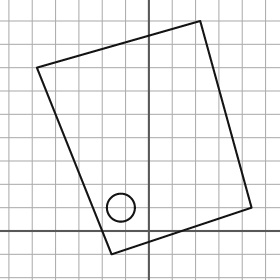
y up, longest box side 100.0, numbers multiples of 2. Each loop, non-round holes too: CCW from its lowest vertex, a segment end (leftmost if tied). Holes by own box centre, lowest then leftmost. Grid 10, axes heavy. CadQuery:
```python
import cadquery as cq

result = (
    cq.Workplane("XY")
    .moveTo(-16.0, -10.0)
    .lineTo(44.0, 10.0)
    .lineTo(22.0, 90.0)
    .lineTo(-48.0, 70.0)
    .close()
    .moveTo(-12.0, 10.0)
    .circle(6.0)
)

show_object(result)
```